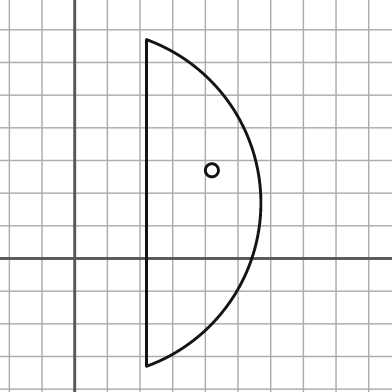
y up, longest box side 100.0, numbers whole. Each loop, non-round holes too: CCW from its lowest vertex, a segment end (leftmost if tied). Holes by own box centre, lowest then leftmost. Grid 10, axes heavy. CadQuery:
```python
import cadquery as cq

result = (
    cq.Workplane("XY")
    .moveTo(22.0, -33.0)
    .threePointArc((57.0, 17.0), (22.0, 67.0))
    .close()
    .moveTo(42.0, 27.0)
    .circle(2.0)
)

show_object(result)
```